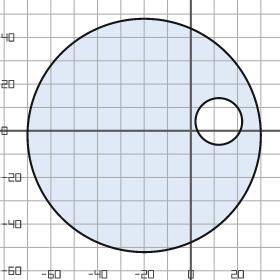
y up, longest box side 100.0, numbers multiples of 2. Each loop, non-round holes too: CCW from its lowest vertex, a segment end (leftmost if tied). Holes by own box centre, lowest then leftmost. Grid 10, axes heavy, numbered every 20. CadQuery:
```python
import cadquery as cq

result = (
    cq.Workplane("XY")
    .moveTo(-20.0, -2.0)
    .circle(50.0)
    .moveTo(12.0, 4.0)
    .circle(10.0)
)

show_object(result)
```